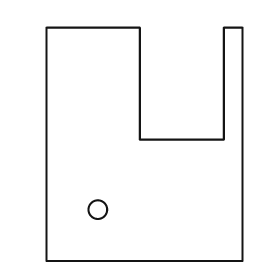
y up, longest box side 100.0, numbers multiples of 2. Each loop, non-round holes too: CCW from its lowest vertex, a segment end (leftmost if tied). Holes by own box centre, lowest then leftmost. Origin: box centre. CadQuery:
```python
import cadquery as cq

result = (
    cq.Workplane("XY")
    .moveTo(-42.0, -50.0)
    .lineTo(42.0, -50.0)
    .lineTo(42.0, 50.0)
    .lineTo(34.0, 50.0)
    .lineTo(34.0, 2.0)
    .lineTo(-2.0, 2.0)
    .lineTo(-2.0, 50.0)
    .lineTo(-42.0, 50.0)
    .close()
    .moveTo(-20.0, -28.0)
    .circle(4.0)
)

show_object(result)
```